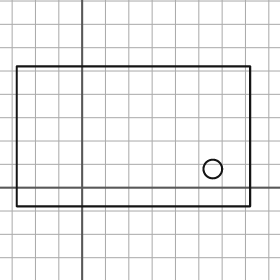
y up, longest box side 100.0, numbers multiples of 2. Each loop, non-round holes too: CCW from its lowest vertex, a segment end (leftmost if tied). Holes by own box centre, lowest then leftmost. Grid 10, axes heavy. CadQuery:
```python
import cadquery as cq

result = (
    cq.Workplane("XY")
    .moveTo(-28.0, -8.0)
    .lineTo(72.0, -8.0)
    .lineTo(72.0, 52.0)
    .lineTo(-28.0, 52.0)
    .close()
    .moveTo(56.0, 8.0)
    .circle(4.0)
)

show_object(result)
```